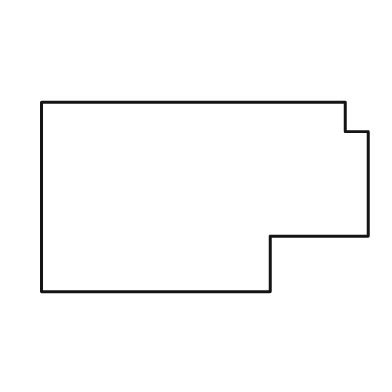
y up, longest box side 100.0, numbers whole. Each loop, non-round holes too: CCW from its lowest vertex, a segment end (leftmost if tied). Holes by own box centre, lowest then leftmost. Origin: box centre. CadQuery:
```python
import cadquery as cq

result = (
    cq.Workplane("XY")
    .moveTo(-50.0, -29.0)
    .lineTo(20.0, -29.0)
    .lineTo(20.0, -12.0)
    .lineTo(50.0, -12.0)
    .lineTo(50.0, 20.0)
    .lineTo(43.0, 20.0)
    .lineTo(43.0, 29.0)
    .lineTo(-50.0, 29.0)
    .close()
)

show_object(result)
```